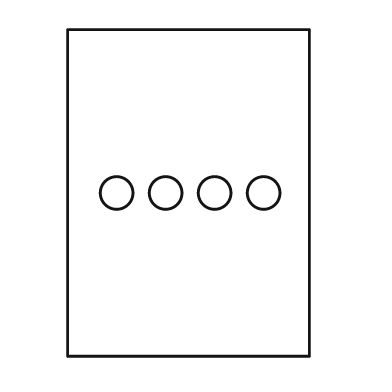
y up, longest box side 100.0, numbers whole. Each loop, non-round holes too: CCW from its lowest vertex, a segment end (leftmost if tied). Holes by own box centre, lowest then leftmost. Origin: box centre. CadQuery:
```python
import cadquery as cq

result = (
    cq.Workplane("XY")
    .moveTo(-37.0, -50.0)
    .lineTo(37.0, -50.0)
    .lineTo(37.0, 50.0)
    .lineTo(-37.0, 50.0)
    .close()
    .moveTo(-22.0, 0.0)
    .circle(5.0)
    .moveTo(-7.0, 0.0)
    .circle(5.0)
    .moveTo(8.0, 0.0)
    .circle(5.0)
    .moveTo(23.0, 0.0)
    .circle(5.0)
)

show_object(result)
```